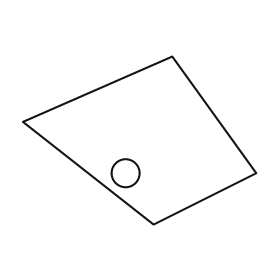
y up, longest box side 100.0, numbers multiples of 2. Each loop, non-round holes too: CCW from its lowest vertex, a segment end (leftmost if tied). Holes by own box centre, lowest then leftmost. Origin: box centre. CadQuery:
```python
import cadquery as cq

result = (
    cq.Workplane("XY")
    .moveTo(6.0, -36.0)
    .lineTo(50.0, -14.0)
    .lineTo(14.0, 36.0)
    .lineTo(-50.0, 8.0)
    .close()
    .moveTo(-6.0, -14.0)
    .circle(6.0)
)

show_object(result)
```